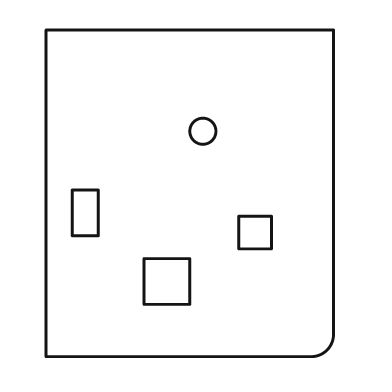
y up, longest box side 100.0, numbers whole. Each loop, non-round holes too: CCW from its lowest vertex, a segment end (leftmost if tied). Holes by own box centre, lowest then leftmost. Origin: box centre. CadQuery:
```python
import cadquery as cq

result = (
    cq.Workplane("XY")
    .moveTo(-44.0, -50.0)
    .lineTo(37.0, -50.0)
    .threePointArc((42.0, -48.0), (44.0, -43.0))
    .lineTo(44.0, 50.0)
    .lineTo(-44.0, 50.0)
    .close()
    .moveTo(-14.0, -34.0)
    .lineTo(0.0, -34.0)
    .lineTo(0.0, -20.0)
    .lineTo(-14.0, -20.0)
    .close()
    .moveTo(15.0, -17.0)
    .lineTo(25.0, -17.0)
    .lineTo(25.0, -7.0)
    .lineTo(15.0, -7.0)
    .close()
    .moveTo(-36.0, -13.0)
    .lineTo(-28.0, -13.0)
    .lineTo(-28.0, 1.0)
    .lineTo(-36.0, 1.0)
    .close()
    .moveTo(4.0, 19.0)
    .circle(4.0)
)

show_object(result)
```